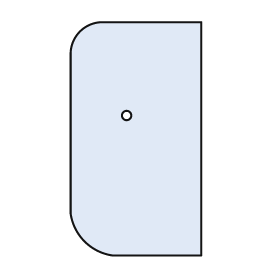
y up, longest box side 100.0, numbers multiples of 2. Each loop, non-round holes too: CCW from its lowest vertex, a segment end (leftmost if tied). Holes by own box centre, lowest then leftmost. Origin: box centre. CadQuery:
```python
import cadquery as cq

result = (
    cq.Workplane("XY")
    .moveTo(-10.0, -50.0)
    .lineTo(28.0, -50.0)
    .lineTo(28.0, 50.0)
    .lineTo(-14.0, 50.0)
    .threePointArc((-24.0, 46.0), (-28.0, 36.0))
    .lineTo(-28.0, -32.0)
    .threePointArc((-22.0, -44.0), (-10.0, -50.0))
    .close()
    .moveTo(-4.0, 10.0)
    .circle(2.0)
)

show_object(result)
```